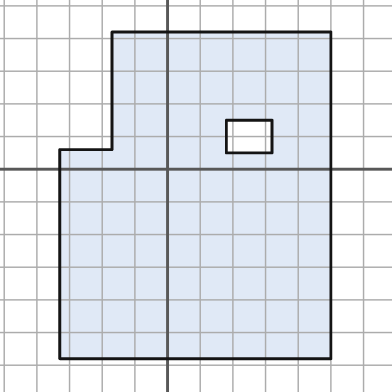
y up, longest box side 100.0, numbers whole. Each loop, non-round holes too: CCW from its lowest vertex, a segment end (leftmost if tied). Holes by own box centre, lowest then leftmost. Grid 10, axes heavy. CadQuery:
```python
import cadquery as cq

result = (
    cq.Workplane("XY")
    .moveTo(-33.0, -58.0)
    .lineTo(50.0, -58.0)
    .lineTo(50.0, 42.0)
    .lineTo(-17.0, 42.0)
    .lineTo(-17.0, 6.0)
    .lineTo(-33.0, 6.0)
    .close()
    .moveTo(18.0, 5.0)
    .lineTo(32.0, 5.0)
    .lineTo(32.0, 15.0)
    .lineTo(18.0, 15.0)
    .close()
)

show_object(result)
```